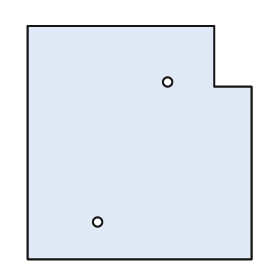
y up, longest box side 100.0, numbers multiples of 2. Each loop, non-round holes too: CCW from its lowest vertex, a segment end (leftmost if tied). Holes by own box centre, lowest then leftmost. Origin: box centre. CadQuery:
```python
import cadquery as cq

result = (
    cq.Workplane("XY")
    .moveTo(-48.0, -50.0)
    .lineTo(48.0, -50.0)
    .lineTo(48.0, 24.0)
    .lineTo(32.0, 24.0)
    .lineTo(32.0, 50.0)
    .lineTo(-48.0, 50.0)
    .close()
    .moveTo(-18.0, -34.0)
    .circle(2.0)
    .moveTo(12.0, 26.0)
    .circle(2.0)
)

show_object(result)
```